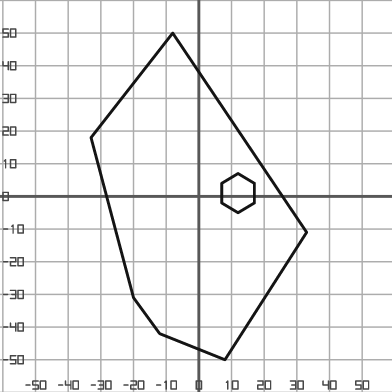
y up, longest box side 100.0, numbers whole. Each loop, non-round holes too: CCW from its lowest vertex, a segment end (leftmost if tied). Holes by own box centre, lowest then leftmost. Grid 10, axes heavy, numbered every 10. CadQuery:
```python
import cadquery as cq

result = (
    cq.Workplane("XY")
    .moveTo(8.0, -50.0)
    .lineTo(33.0, -11.0)
    .lineTo(-8.0, 50.0)
    .lineTo(-33.0, 18.0)
    .lineTo(-20.0, -31.0)
    .lineTo(-12.0, -42.0)
    .close()
    .moveTo(12.0, -5.0)
    .lineTo(17.0, -2.0)
    .lineTo(17.0, 4.0)
    .lineTo(12.0, 7.0)
    .lineTo(7.0, 4.0)
    .lineTo(7.0, -2.0)
    .close()
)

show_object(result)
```